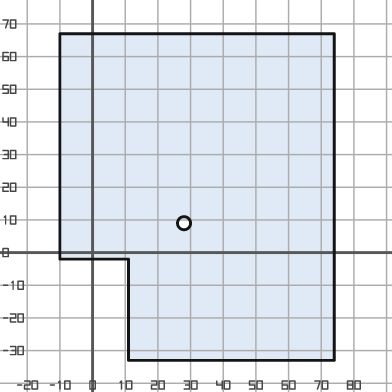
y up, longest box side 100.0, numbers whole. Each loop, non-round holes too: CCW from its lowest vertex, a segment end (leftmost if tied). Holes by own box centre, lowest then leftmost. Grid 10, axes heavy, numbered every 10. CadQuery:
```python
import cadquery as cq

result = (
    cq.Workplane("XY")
    .moveTo(11.0, -33.0)
    .lineTo(74.0, -33.0)
    .lineTo(74.0, 67.0)
    .lineTo(-10.0, 67.0)
    .lineTo(-10.0, -2.0)
    .lineTo(11.0, -2.0)
    .close()
    .moveTo(28.0, 9.0)
    .circle(2.0)
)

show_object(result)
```